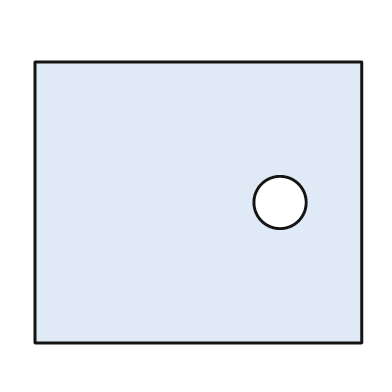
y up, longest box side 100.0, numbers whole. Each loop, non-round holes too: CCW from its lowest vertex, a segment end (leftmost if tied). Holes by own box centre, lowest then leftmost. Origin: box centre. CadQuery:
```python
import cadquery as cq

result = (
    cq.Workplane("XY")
    .moveTo(-50.0, -43.0)
    .lineTo(50.0, -43.0)
    .lineTo(50.0, 43.0)
    .lineTo(-50.0, 43.0)
    .close()
    .moveTo(25.0, 0.0)
    .circle(8.0)
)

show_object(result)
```